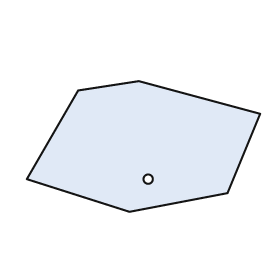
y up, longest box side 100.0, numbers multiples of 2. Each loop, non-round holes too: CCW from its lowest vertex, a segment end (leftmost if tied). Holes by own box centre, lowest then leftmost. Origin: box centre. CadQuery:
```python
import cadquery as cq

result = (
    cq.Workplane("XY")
    .moveTo(-6.0, -28.0)
    .lineTo(36.0, -20.0)
    .lineTo(50.0, 14.0)
    .lineTo(-2.0, 28.0)
    .lineTo(-28.0, 24.0)
    .lineTo(-50.0, -14.0)
    .close()
    .moveTo(2.0, -14.0)
    .circle(2.0)
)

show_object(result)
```